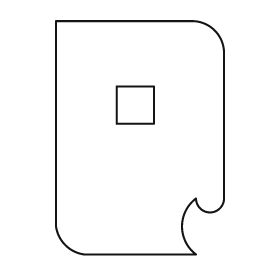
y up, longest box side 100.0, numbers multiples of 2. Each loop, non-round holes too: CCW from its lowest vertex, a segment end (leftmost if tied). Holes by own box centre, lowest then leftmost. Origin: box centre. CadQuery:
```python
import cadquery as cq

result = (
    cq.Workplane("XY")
    .moveTo(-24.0, -50.0)
    .lineTo(24.0, -50.0)
    .threePointArc((18.0, -38.0), (24.0, -26.0))
    .threePointArc((30.0, -32.0), (36.0, -26.0))
    .lineTo(36.0, 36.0)
    .threePointArc((32.0, 46.0), (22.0, 50.0))
    .lineTo(-36.0, 50.0)
    .lineTo(-36.0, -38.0)
    .threePointArc((-32.0, -46.0), (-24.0, -50.0))
    .close()
    .moveTo(-10.0, 6.0)
    .lineTo(6.0, 6.0)
    .lineTo(6.0, 22.0)
    .lineTo(-10.0, 22.0)
    .close()
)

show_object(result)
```